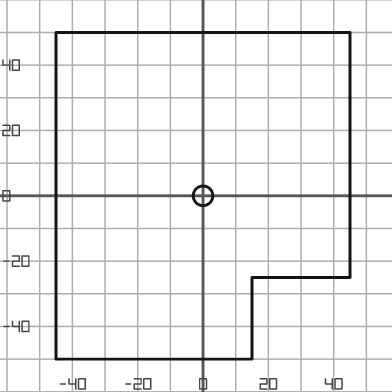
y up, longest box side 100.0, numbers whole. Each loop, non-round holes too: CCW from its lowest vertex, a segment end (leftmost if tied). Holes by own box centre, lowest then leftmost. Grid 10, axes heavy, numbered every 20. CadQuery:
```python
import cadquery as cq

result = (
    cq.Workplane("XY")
    .moveTo(-45.0, -50.0)
    .lineTo(15.0, -50.0)
    .lineTo(15.0, -25.0)
    .lineTo(45.0, -25.0)
    .lineTo(45.0, 50.0)
    .lineTo(-45.0, 50.0)
    .close()
    .moveTo(0.0, 0.0)
    .circle(3.0)
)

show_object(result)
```